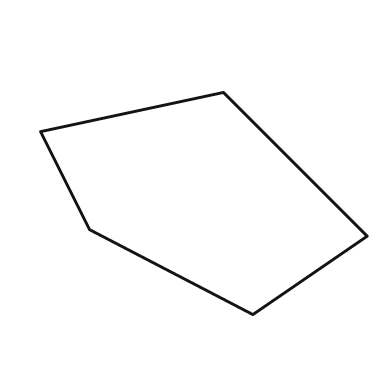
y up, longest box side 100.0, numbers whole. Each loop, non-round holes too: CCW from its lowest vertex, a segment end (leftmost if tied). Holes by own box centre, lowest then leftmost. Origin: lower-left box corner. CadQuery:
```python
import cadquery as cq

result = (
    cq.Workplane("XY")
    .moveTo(65.0, 0.0)
    .lineTo(100.0, 24.0)
    .lineTo(56.0, 68.0)
    .lineTo(0.0, 56.0)
    .lineTo(15.0, 26.0)
    .close()
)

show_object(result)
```